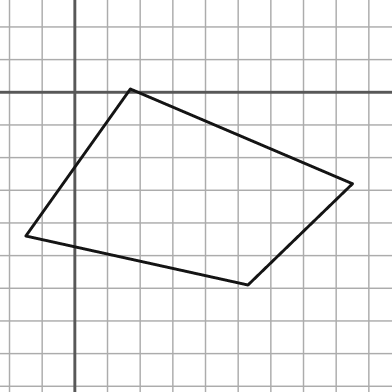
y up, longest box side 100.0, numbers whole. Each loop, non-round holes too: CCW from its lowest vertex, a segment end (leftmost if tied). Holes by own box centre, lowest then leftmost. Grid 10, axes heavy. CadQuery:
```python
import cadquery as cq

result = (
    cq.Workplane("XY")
    .moveTo(53.0, -59.0)
    .lineTo(85.0, -28.0)
    .lineTo(17.0, 1.0)
    .lineTo(-15.0, -44.0)
    .close()
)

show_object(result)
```